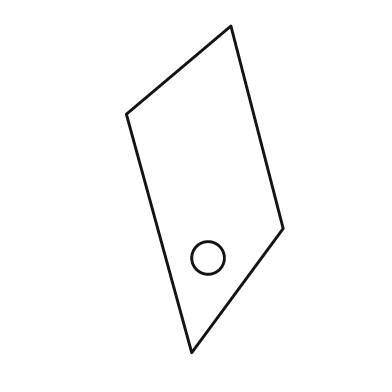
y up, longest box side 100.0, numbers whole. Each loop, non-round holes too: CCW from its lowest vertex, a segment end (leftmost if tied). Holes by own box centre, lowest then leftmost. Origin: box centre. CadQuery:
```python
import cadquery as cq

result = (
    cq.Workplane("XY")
    .moveTo(-4.0, -50.0)
    .lineTo(24.0, -12.0)
    .lineTo(8.0, 50.0)
    .lineTo(-24.0, 23.0)
    .close()
    .moveTo(1.0, -21.0)
    .circle(5.0)
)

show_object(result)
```